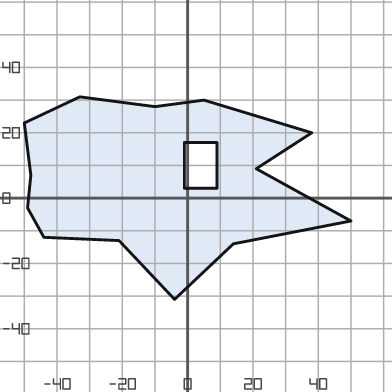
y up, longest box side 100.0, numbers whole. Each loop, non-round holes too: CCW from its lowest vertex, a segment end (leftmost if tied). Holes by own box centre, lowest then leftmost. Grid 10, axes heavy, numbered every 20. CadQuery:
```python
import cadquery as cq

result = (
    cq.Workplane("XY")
    .moveTo(-4.0, -31.0)
    .lineTo(14.0, -14.0)
    .lineTo(50.0, -7.0)
    .lineTo(21.0, 9.0)
    .lineTo(38.0, 20.0)
    .lineTo(5.0, 30.0)
    .lineTo(-10.0, 28.0)
    .lineTo(-33.0, 31.0)
    .lineTo(-50.0, 23.0)
    .lineTo(-48.0, 7.0)
    .lineTo(-49.0, -3.0)
    .lineTo(-44.0, -12.0)
    .lineTo(-21.0, -13.0)
    .close()
    .moveTo(-1.0, 3.0)
    .lineTo(9.0, 3.0)
    .lineTo(9.0, 17.0)
    .lineTo(-1.0, 17.0)
    .close()
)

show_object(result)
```